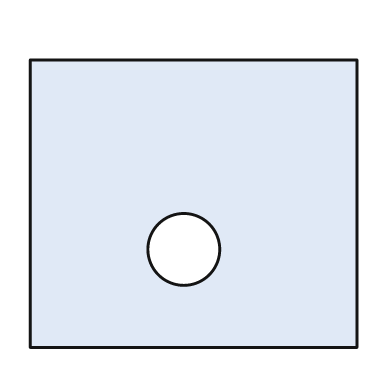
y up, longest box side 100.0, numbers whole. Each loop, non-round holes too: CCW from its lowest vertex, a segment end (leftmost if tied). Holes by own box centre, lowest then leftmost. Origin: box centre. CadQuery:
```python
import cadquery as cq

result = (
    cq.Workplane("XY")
    .moveTo(-50.0, -44.0)
    .lineTo(50.0, -44.0)
    .lineTo(50.0, 44.0)
    .lineTo(-50.0, 44.0)
    .close()
    .moveTo(-3.0, -14.0)
    .circle(11.0)
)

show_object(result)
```